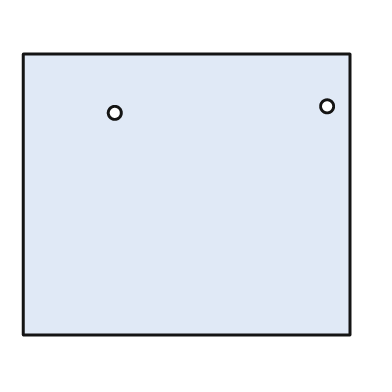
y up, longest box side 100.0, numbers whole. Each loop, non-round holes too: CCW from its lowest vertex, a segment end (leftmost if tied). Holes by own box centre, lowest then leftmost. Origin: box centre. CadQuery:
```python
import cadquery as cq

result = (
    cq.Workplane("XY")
    .moveTo(-50.0, -43.0)
    .lineTo(50.0, -43.0)
    .lineTo(50.0, 43.0)
    .lineTo(-50.0, 43.0)
    .close()
    .moveTo(-22.0, 25.0)
    .circle(2.0)
    .moveTo(43.0, 27.0)
    .circle(2.0)
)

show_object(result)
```